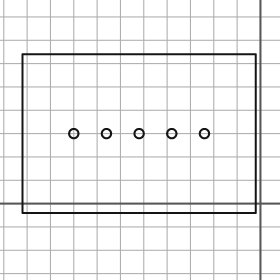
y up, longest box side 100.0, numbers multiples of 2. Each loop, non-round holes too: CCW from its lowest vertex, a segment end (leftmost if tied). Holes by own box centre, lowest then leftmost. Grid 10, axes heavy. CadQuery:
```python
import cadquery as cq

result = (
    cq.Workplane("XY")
    .moveTo(-102.0, -4.0)
    .lineTo(-2.0, -4.0)
    .lineTo(-2.0, 64.0)
    .lineTo(-102.0, 64.0)
    .close()
    .moveTo(-80.0, 30.0)
    .circle(2.0)
    .moveTo(-66.0, 30.0)
    .circle(2.0)
    .moveTo(-52.0, 30.0)
    .circle(2.0)
    .moveTo(-38.0, 30.0)
    .circle(2.0)
    .moveTo(-24.0, 30.0)
    .circle(2.0)
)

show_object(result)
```